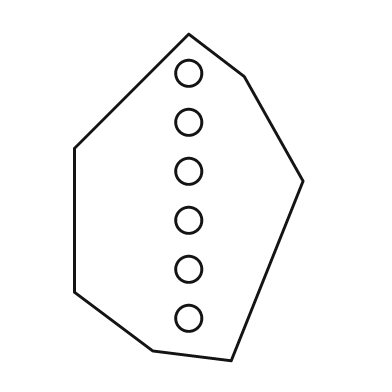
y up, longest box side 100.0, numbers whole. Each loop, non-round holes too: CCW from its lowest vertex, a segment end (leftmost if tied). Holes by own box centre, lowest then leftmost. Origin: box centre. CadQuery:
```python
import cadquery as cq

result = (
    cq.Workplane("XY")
    .moveTo(13.0, -50.0)
    .lineTo(35.0, 5.0)
    .lineTo(17.0, 37.0)
    .lineTo(0.0, 50.0)
    .lineTo(-35.0, 15.0)
    .lineTo(-35.0, -29.0)
    .lineTo(-11.0, -47.0)
    .close()
    .moveTo(0.0, -37.0)
    .circle(4.0)
    .moveTo(0.0, -22.0)
    .circle(4.0)
    .moveTo(0.0, -7.0)
    .circle(4.0)
    .moveTo(0.0, 8.0)
    .circle(4.0)
    .moveTo(0.0, 23.0)
    .circle(4.0)
    .moveTo(0.0, 38.0)
    .circle(4.0)
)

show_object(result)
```